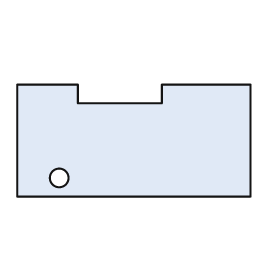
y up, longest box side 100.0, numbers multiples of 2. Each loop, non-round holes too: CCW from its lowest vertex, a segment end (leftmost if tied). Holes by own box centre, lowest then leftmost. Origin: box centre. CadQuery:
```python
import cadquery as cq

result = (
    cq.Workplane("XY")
    .moveTo(-50.0, -24.0)
    .lineTo(50.0, -24.0)
    .lineTo(50.0, 24.0)
    .lineTo(12.0, 24.0)
    .lineTo(12.0, 16.0)
    .lineTo(-24.0, 16.0)
    .lineTo(-24.0, 24.0)
    .lineTo(-50.0, 24.0)
    .close()
    .moveTo(-32.0, -16.0)
    .circle(4.0)
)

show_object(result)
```